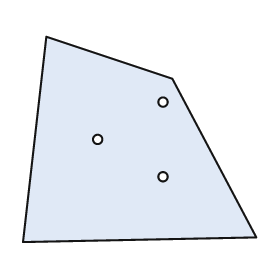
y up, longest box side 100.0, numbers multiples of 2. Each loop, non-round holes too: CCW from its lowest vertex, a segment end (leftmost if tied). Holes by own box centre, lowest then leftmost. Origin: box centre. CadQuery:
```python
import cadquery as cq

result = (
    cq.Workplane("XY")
    .moveTo(-50.0, -44.0)
    .lineTo(50.0, -42.0)
    .lineTo(14.0, 26.0)
    .lineTo(-40.0, 44.0)
    .close()
    .moveTo(10.0, -16.0)
    .circle(2.0)
    .moveTo(-18.0, 0.0)
    .circle(2.0)
    .moveTo(10.0, 16.0)
    .circle(2.0)
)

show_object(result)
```